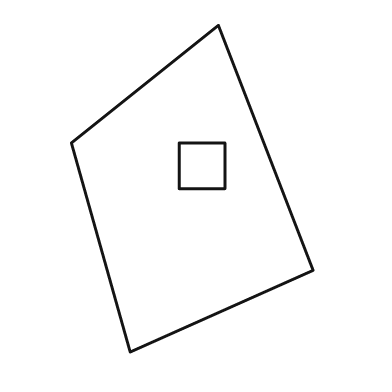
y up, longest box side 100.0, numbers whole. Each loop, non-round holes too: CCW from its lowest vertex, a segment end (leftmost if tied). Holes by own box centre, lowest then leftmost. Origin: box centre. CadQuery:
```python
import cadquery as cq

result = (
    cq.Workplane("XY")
    .moveTo(-19.0, -50.0)
    .lineTo(37.0, -25.0)
    .lineTo(8.0, 50.0)
    .lineTo(-37.0, 14.0)
    .close()
    .moveTo(-4.0, 0.0)
    .lineTo(10.0, 0.0)
    .lineTo(10.0, 14.0)
    .lineTo(-4.0, 14.0)
    .close()
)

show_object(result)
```